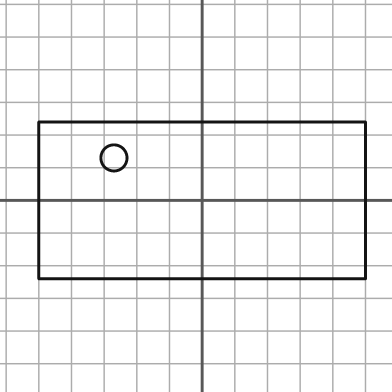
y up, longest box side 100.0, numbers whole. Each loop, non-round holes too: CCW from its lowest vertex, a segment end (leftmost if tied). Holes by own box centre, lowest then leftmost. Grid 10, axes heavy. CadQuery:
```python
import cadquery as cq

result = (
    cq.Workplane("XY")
    .moveTo(-50.0, -24.0)
    .lineTo(50.0, -24.0)
    .lineTo(50.0, 24.0)
    .lineTo(-50.0, 24.0)
    .close()
    .moveTo(-27.0, 13.0)
    .circle(4.0)
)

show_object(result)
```